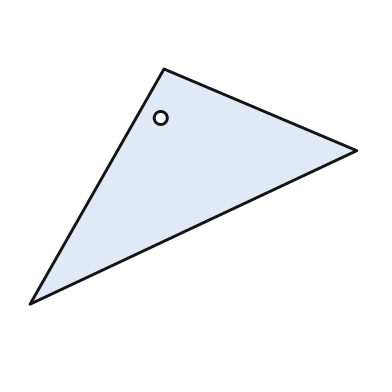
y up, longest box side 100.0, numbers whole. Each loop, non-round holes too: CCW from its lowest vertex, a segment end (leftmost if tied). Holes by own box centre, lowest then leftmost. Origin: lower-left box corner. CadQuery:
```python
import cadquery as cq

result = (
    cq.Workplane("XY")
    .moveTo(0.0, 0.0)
    .lineTo(100.0, 47.0)
    .lineTo(41.0, 72.0)
    .close()
    .moveTo(40.0, 57.0)
    .circle(2.0)
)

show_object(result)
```